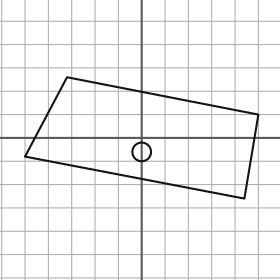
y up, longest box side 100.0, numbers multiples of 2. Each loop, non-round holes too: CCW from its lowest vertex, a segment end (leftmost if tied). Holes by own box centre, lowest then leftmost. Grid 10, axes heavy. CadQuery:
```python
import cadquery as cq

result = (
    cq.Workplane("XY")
    .moveTo(44.0, -26.0)
    .lineTo(50.0, 10.0)
    .lineTo(-32.0, 26.0)
    .lineTo(-50.0, -8.0)
    .close()
    .moveTo(0.0, -6.0)
    .circle(4.0)
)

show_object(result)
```